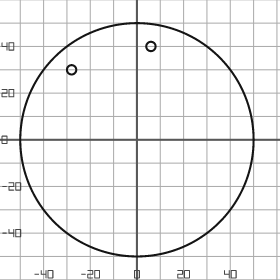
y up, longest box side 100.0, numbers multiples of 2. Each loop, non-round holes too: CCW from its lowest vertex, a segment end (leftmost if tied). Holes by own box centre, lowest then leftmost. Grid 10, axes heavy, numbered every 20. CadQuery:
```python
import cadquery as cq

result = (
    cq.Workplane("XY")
    .moveTo(0.0, 0.0)
    .circle(50.0)
    .moveTo(-28.0, 30.0)
    .circle(2.0)
    .moveTo(6.0, 40.0)
    .circle(2.0)
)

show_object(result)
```